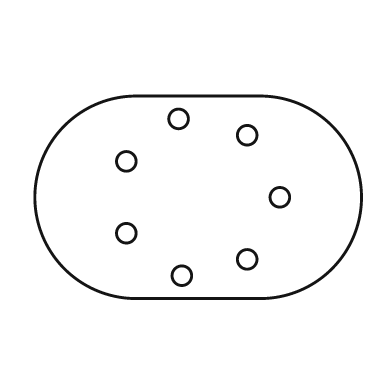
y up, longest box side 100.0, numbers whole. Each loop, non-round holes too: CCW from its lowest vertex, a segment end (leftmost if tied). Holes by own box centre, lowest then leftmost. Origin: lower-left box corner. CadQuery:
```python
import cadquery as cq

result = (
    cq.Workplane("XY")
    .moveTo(31.0, 0.0)
    .lineTo(69.0, 0.0)
    .threePointArc((100.0, 31.0), (69.0, 62.0))
    .lineTo(31.0, 62.0)
    .threePointArc((0.0, 31.0), (31.0, 0.0))
    .close()
    .moveTo(45.0, 7.0)
    .circle(3.0)
    .moveTo(65.0, 12.0)
    .circle(3.0)
    .moveTo(28.0, 20.0)
    .circle(3.0)
    .moveTo(75.0, 31.0)
    .circle(3.0)
    .moveTo(28.0, 42.0)
    .circle(3.0)
    .moveTo(65.0, 50.0)
    .circle(3.0)
    .moveTo(44.0, 55.0)
    .circle(3.0)
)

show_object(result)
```